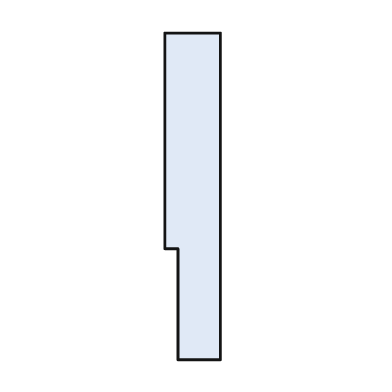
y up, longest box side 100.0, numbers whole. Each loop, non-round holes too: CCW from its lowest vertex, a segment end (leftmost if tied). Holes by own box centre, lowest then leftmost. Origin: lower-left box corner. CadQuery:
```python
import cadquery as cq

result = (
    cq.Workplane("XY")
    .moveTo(4.0, 0.0)
    .lineTo(17.0, 0.0)
    .lineTo(17.0, 100.0)
    .lineTo(0.0, 100.0)
    .lineTo(0.0, 34.0)
    .lineTo(4.0, 34.0)
    .close()
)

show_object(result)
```